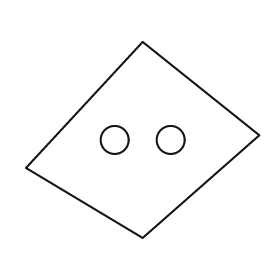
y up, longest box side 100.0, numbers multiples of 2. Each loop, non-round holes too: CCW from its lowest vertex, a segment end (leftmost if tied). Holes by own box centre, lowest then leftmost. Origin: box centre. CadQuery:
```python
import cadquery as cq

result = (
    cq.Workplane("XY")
    .moveTo(0.0, -42.0)
    .lineTo(50.0, 2.0)
    .lineTo(0.0, 42.0)
    .lineTo(-50.0, -12.0)
    .close()
    .moveTo(-12.0, 0.0)
    .circle(6.0)
    .moveTo(12.0, 0.0)
    .circle(6.0)
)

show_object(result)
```